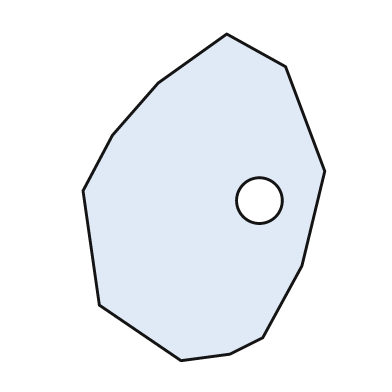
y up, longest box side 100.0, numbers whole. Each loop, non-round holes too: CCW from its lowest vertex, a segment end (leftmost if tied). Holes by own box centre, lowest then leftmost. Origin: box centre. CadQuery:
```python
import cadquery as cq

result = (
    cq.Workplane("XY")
    .moveTo(-7.0, -50.0)
    .lineTo(8.0, -48.0)
    .lineTo(18.0, -43.0)
    .lineTo(30.0, -21.0)
    .lineTo(37.0, 8.0)
    .lineTo(25.0, 40.0)
    .lineTo(7.0, 50.0)
    .lineTo(-14.0, 35.0)
    .lineTo(-28.0, 19.0)
    .lineTo(-37.0, 2.0)
    .lineTo(-32.0, -33.0)
    .close()
    .moveTo(17.0, -1.0)
    .circle(7.0)
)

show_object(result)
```